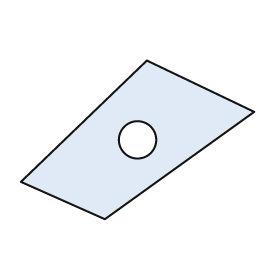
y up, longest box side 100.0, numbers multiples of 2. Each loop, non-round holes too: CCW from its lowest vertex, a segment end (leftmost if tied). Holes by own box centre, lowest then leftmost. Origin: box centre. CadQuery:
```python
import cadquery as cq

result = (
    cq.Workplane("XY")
    .moveTo(-14.0, -34.0)
    .lineTo(50.0, 12.0)
    .lineTo(4.0, 34.0)
    .lineTo(-50.0, -18.0)
    .close()
    .moveTo(0.0, 0.0)
    .circle(8.0)
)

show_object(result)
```